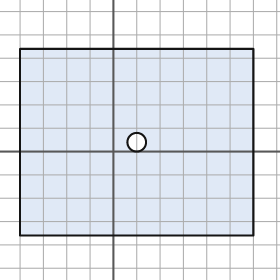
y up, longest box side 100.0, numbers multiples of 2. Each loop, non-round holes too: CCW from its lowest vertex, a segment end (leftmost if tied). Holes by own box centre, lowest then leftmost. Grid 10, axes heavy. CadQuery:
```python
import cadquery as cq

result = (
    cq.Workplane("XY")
    .moveTo(-40.0, -36.0)
    .lineTo(60.0, -36.0)
    .lineTo(60.0, 44.0)
    .lineTo(-40.0, 44.0)
    .close()
    .moveTo(10.0, 4.0)
    .circle(4.0)
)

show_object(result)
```